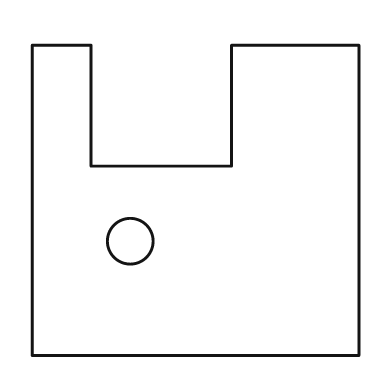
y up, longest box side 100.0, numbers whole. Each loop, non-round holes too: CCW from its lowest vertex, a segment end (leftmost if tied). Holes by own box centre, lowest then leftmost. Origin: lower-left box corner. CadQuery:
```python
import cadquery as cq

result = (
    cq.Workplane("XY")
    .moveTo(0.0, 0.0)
    .lineTo(100.0, 0.0)
    .lineTo(100.0, 95.0)
    .lineTo(61.0, 95.0)
    .lineTo(61.0, 58.0)
    .lineTo(18.0, 58.0)
    .lineTo(18.0, 95.0)
    .lineTo(0.0, 95.0)
    .close()
    .moveTo(30.0, 35.0)
    .circle(7.0)
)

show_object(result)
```